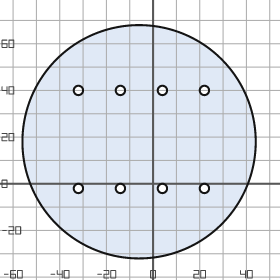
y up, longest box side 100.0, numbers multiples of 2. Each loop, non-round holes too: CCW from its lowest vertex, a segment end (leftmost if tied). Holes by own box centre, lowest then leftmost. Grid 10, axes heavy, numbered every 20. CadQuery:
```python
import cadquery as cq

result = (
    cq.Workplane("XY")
    .moveTo(-6.0, 18.0)
    .circle(50.0)
    .moveTo(-32.0, -2.0)
    .circle(2.0)
    .moveTo(-14.0, -2.0)
    .circle(2.0)
    .moveTo(4.0, -2.0)
    .circle(2.0)
    .moveTo(22.0, -2.0)
    .circle(2.0)
    .moveTo(-32.0, 40.0)
    .circle(2.0)
    .moveTo(-14.0, 40.0)
    .circle(2.0)
    .moveTo(4.0, 40.0)
    .circle(2.0)
    .moveTo(22.0, 40.0)
    .circle(2.0)
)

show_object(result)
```